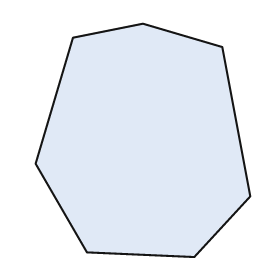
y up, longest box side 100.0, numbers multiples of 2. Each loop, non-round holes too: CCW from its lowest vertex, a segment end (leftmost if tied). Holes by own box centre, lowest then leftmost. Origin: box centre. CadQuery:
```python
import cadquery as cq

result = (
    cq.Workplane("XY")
    .moveTo(22.0, -50.0)
    .lineTo(46.0, -24.0)
    .lineTo(34.0, 40.0)
    .lineTo(0.0, 50.0)
    .lineTo(-30.0, 44.0)
    .lineTo(-46.0, -10.0)
    .lineTo(-24.0, -48.0)
    .close()
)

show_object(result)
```